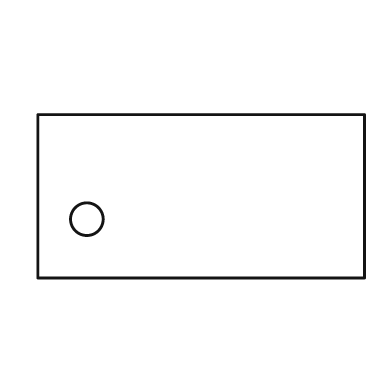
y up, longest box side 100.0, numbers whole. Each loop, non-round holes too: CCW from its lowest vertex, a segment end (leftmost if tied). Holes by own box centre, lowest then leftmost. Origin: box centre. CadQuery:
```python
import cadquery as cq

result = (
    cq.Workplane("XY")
    .moveTo(-50.0, -25.0)
    .lineTo(50.0, -25.0)
    .lineTo(50.0, 25.0)
    .lineTo(-50.0, 25.0)
    .close()
    .moveTo(-35.0, -7.0)
    .circle(5.0)
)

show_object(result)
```